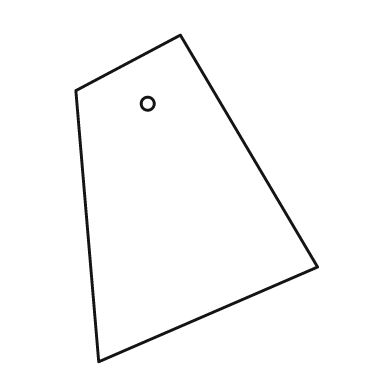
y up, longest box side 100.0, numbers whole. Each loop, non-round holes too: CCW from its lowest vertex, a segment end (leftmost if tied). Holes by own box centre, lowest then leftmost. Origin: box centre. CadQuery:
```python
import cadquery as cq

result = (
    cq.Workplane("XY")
    .moveTo(-30.0, -50.0)
    .lineTo(37.0, -21.0)
    .lineTo(-5.0, 50.0)
    .lineTo(-37.0, 33.0)
    .close()
    .moveTo(-15.0, 29.0)
    .circle(2.0)
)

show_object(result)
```